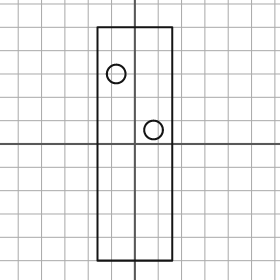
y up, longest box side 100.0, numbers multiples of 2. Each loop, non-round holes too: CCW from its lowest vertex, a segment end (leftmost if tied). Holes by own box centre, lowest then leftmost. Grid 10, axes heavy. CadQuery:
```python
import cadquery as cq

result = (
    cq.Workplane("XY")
    .moveTo(-16.0, -50.0)
    .lineTo(16.0, -50.0)
    .lineTo(16.0, 50.0)
    .lineTo(-16.0, 50.0)
    .close()
    .moveTo(8.0, 6.0)
    .circle(4.0)
    .moveTo(-8.0, 30.0)
    .circle(4.0)
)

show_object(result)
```